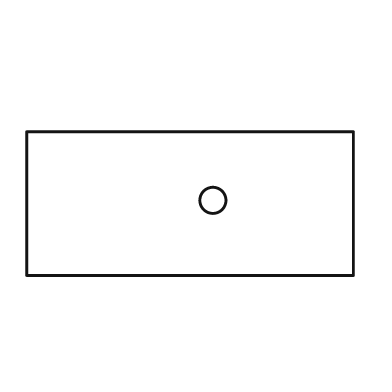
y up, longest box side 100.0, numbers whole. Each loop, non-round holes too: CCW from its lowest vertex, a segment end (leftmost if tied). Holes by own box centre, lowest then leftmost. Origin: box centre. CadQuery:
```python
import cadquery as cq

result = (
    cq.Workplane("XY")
    .moveTo(-50.0, -22.0)
    .lineTo(50.0, -22.0)
    .lineTo(50.0, 22.0)
    .lineTo(-50.0, 22.0)
    .close()
    .moveTo(7.0, 1.0)
    .circle(4.0)
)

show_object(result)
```